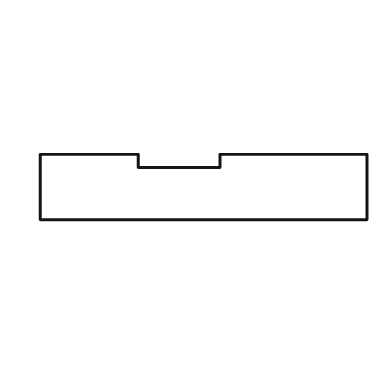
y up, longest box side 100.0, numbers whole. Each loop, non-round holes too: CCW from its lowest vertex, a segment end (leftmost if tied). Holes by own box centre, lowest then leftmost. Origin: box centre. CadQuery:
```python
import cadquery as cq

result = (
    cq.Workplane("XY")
    .moveTo(-50.0, -10.0)
    .lineTo(50.0, -10.0)
    .lineTo(50.0, 10.0)
    .lineTo(5.0, 10.0)
    .lineTo(5.0, 6.0)
    .lineTo(-20.0, 6.0)
    .lineTo(-20.0, 10.0)
    .lineTo(-50.0, 10.0)
    .close()
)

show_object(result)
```